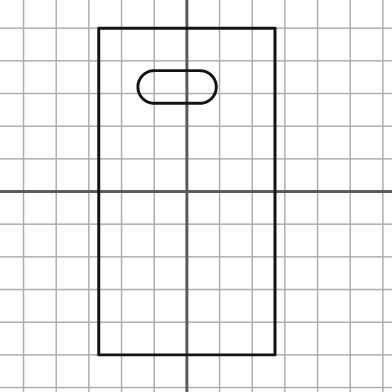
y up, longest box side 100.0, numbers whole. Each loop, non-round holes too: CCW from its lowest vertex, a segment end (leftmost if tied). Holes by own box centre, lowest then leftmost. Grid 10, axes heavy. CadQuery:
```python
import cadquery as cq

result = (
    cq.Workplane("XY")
    .moveTo(-27.0, -50.0)
    .lineTo(27.0, -50.0)
    .lineTo(27.0, 50.0)
    .lineTo(-27.0, 50.0)
    .close()
    .moveTo(-10.0, 27.0)
    .lineTo(4.0, 27.0)
    .threePointArc((9.0, 32.0), (4.0, 37.0))
    .lineTo(-10.0, 37.0)
    .threePointArc((-15.0, 32.0), (-10.0, 27.0))
    .close()
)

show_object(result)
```